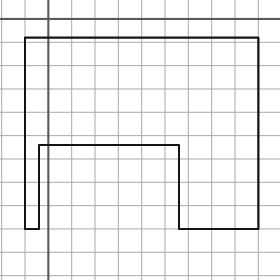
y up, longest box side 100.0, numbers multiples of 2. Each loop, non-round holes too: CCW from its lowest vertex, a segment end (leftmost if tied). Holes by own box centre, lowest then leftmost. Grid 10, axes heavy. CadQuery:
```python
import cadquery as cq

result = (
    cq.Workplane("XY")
    .moveTo(-10.0, -90.0)
    .lineTo(-4.0, -90.0)
    .lineTo(-4.0, -54.0)
    .lineTo(56.0, -54.0)
    .lineTo(56.0, -90.0)
    .lineTo(90.0, -90.0)
    .lineTo(90.0, -8.0)
    .lineTo(-10.0, -8.0)
    .close()
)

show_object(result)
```